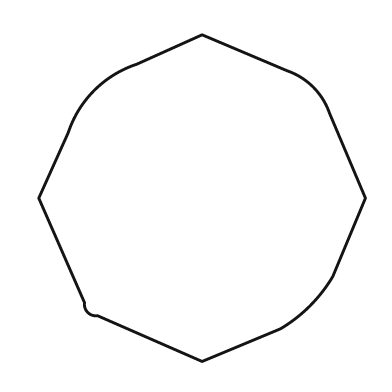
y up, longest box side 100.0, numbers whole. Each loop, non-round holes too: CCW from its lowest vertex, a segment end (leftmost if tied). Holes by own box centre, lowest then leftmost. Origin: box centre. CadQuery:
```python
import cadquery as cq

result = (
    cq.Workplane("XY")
    .moveTo(0.0, -50.0)
    .lineTo(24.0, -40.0)
    .threePointArc((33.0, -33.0), (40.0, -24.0))
    .lineTo(50.0, 0.0)
    .lineTo(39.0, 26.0)
    .threePointArc((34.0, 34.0), (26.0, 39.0))
    .lineTo(0.0, 50.0)
    .lineTo(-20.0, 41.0)
    .threePointArc((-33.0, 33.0), (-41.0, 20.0))
    .lineTo(-50.0, 0.0)
    .lineTo(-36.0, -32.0)
    .threePointArc((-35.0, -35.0), (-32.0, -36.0))
    .close()
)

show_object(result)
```